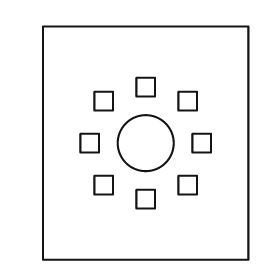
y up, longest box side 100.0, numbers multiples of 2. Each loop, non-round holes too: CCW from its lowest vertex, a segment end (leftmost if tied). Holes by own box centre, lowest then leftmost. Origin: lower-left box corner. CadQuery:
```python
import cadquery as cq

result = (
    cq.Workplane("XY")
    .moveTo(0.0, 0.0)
    .lineTo(88.0, 0.0)
    .lineTo(88.0, 100.0)
    .lineTo(0.0, 100.0)
    .close()
    .moveTo(40.0, 22.0)
    .lineTo(48.0, 22.0)
    .lineTo(48.0, 30.0)
    .lineTo(40.0, 30.0)
    .close()
    .moveTo(22.0, 28.0)
    .lineTo(30.0, 28.0)
    .lineTo(30.0, 36.0)
    .lineTo(22.0, 36.0)
    .close()
    .moveTo(58.0, 28.0)
    .lineTo(66.0, 28.0)
    .lineTo(66.0, 36.0)
    .lineTo(58.0, 36.0)
    .close()
    .moveTo(16.0, 46.0)
    .lineTo(24.0, 46.0)
    .lineTo(24.0, 54.0)
    .lineTo(16.0, 54.0)
    .close()
    .moveTo(44.0, 50.0)
    .circle(12.0)
    .moveTo(64.0, 46.0)
    .lineTo(72.0, 46.0)
    .lineTo(72.0, 54.0)
    .lineTo(64.0, 54.0)
    .close()
    .moveTo(22.0, 64.0)
    .lineTo(30.0, 64.0)
    .lineTo(30.0, 72.0)
    .lineTo(22.0, 72.0)
    .close()
    .moveTo(58.0, 64.0)
    .lineTo(66.0, 64.0)
    .lineTo(66.0, 72.0)
    .lineTo(58.0, 72.0)
    .close()
    .moveTo(40.0, 70.0)
    .lineTo(48.0, 70.0)
    .lineTo(48.0, 78.0)
    .lineTo(40.0, 78.0)
    .close()
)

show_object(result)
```